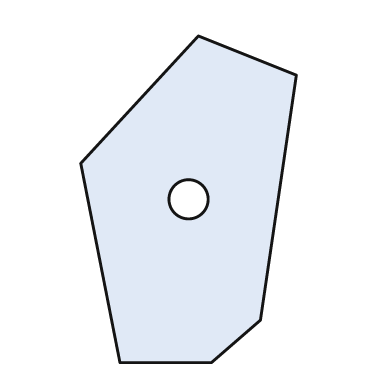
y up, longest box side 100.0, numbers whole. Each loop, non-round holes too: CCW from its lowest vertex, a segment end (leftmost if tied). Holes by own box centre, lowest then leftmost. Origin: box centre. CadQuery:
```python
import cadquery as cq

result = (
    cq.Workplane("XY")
    .moveTo(-21.0, -50.0)
    .lineTo(7.0, -50.0)
    .lineTo(22.0, -37.0)
    .lineTo(33.0, 38.0)
    .lineTo(3.0, 50.0)
    .lineTo(-33.0, 11.0)
    .close()
    .moveTo(0.0, 0.0)
    .circle(6.0)
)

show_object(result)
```